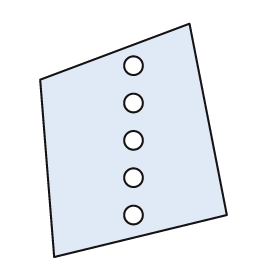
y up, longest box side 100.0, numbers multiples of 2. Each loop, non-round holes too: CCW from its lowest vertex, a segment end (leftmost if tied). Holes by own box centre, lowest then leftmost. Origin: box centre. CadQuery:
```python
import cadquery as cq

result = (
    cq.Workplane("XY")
    .moveTo(-34.0, -50.0)
    .lineTo(40.0, -32.0)
    .lineTo(24.0, 50.0)
    .lineTo(-40.0, 26.0)
    .close()
    .moveTo(0.0, -32.0)
    .circle(4.0)
    .moveTo(0.0, -16.0)
    .circle(4.0)
    .moveTo(0.0, 0.0)
    .circle(4.0)
    .moveTo(0.0, 16.0)
    .circle(4.0)
    .moveTo(0.0, 32.0)
    .circle(4.0)
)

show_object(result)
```